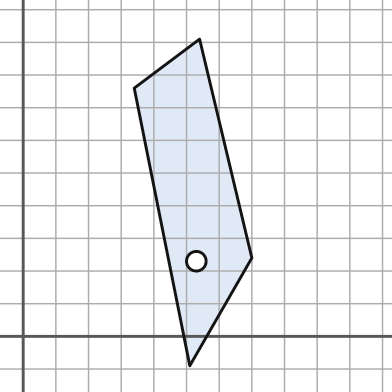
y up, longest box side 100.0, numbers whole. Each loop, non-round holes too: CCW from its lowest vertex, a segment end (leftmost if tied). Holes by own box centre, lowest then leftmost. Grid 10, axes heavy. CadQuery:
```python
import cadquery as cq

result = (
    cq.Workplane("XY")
    .moveTo(51.0, -9.0)
    .lineTo(70.0, 24.0)
    .lineTo(54.0, 91.0)
    .lineTo(34.0, 76.0)
    .close()
    .moveTo(53.0, 23.0)
    .circle(3.0)
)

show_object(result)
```